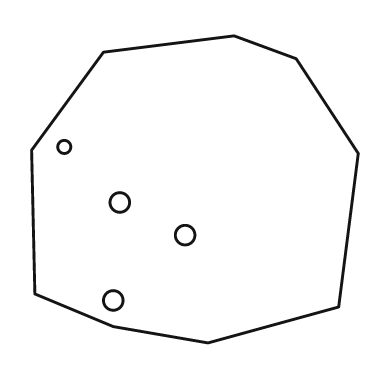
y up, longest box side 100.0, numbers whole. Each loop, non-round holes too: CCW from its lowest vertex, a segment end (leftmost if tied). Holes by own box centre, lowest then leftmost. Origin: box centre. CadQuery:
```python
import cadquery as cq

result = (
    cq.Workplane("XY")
    .moveTo(4.0, -47.0)
    .lineTo(44.0, -36.0)
    .lineTo(50.0, 11.0)
    .lineTo(31.0, 40.0)
    .lineTo(12.0, 47.0)
    .lineTo(-28.0, 42.0)
    .lineTo(-50.0, 12.0)
    .lineTo(-49.0, -32.0)
    .lineTo(-25.0, -42.0)
    .close()
    .moveTo(-25.0, -34.0)
    .circle(3.0)
    .moveTo(-3.0, -14.0)
    .circle(3.0)
    .moveTo(-23.0, -4.0)
    .circle(3.0)
    .moveTo(-40.0, 13.0)
    .circle(2.0)
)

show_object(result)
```